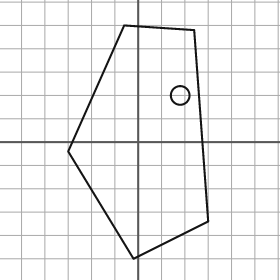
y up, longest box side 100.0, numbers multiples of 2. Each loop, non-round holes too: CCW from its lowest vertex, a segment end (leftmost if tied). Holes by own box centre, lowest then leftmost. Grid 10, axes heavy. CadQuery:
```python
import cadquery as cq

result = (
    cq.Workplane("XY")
    .moveTo(-2.0, -50.0)
    .lineTo(30.0, -34.0)
    .lineTo(24.0, 48.0)
    .lineTo(-6.0, 50.0)
    .lineTo(-30.0, -4.0)
    .close()
    .moveTo(18.0, 20.0)
    .circle(4.0)
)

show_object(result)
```